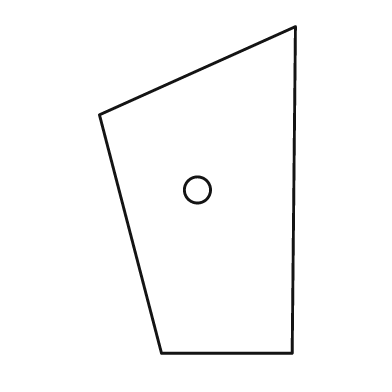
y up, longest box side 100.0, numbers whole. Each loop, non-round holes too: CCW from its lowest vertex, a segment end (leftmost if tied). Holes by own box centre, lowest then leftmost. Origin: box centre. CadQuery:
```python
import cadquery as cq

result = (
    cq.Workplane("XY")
    .moveTo(-11.0, -50.0)
    .lineTo(29.0, -50.0)
    .lineTo(30.0, 50.0)
    .lineTo(-30.0, 23.0)
    .close()
    .moveTo(0.0, 0.0)
    .circle(4.0)
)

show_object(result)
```